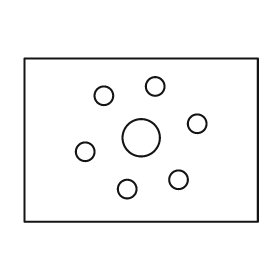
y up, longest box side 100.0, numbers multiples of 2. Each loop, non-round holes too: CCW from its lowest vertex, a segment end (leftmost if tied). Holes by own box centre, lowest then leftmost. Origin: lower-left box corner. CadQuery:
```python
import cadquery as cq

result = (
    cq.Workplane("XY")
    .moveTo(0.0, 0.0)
    .lineTo(100.0, 0.0)
    .lineTo(100.0, 70.0)
    .lineTo(0.0, 70.0)
    .close()
    .moveTo(44.0, 14.0)
    .circle(4.0)
    .moveTo(66.0, 18.0)
    .circle(4.0)
    .moveTo(26.0, 30.0)
    .circle(4.0)
    .moveTo(50.0, 36.0)
    .circle(8.0)
    .moveTo(74.0, 42.0)
    .circle(4.0)
    .moveTo(34.0, 54.0)
    .circle(4.0)
    .moveTo(56.0, 58.0)
    .circle(4.0)
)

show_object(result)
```